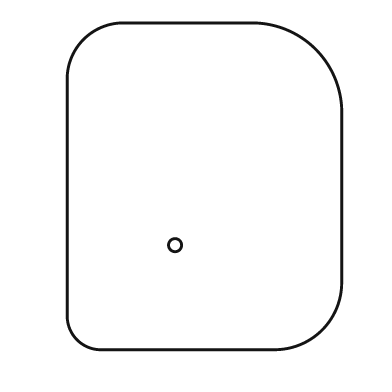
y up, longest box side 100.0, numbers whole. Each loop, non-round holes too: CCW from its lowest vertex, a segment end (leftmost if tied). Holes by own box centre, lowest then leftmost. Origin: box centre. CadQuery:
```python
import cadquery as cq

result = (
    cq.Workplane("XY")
    .moveTo(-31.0, -50.0)
    .lineTo(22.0, -50.0)
    .threePointArc((36.0, -44.0), (42.0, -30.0))
    .lineTo(42.0, 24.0)
    .threePointArc((34.0, 42.0), (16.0, 50.0))
    .lineTo(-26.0, 50.0)
    .threePointArc((-37.0, 45.0), (-42.0, 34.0))
    .lineTo(-42.0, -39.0)
    .threePointArc((-39.0, -47.0), (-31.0, -50.0))
    .close()
    .moveTo(-9.0, -18.0)
    .circle(2.0)
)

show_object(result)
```